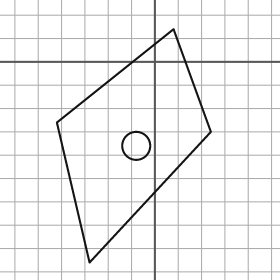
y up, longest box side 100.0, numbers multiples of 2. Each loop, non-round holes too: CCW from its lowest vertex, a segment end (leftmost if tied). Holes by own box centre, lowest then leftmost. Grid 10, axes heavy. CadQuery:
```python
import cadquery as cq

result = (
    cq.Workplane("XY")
    .moveTo(-28.0, -86.0)
    .lineTo(24.0, -30.0)
    .lineTo(8.0, 14.0)
    .lineTo(-42.0, -26.0)
    .close()
    .moveTo(-8.0, -36.0)
    .circle(6.0)
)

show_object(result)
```